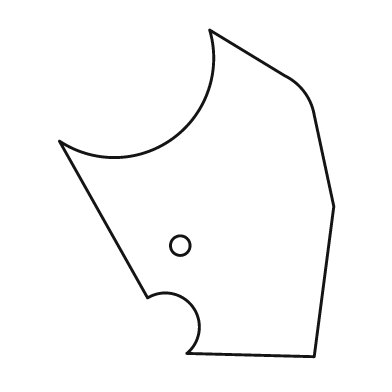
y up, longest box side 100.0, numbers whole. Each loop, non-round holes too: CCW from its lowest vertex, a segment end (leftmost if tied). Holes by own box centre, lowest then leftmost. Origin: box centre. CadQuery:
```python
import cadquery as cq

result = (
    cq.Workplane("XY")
    .moveTo(36.0, -50.0)
    .lineTo(42.0, -4.0)
    .lineTo(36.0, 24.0)
    .threePointArc((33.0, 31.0), (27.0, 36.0))
    .lineTo(4.0, 50.0)
    .threePointArc((-7.0, 17.0), (-42.0, 16.0))
    .lineTo(-15.0, -32.0)
    .threePointArc((-1.0, -35.0), (-3.0, -49.0))
    .close()
    .moveTo(-5.0, -16.0)
    .circle(3.0)
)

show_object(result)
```